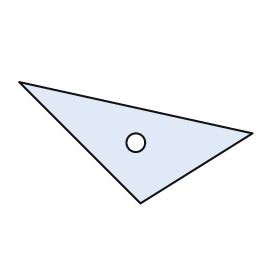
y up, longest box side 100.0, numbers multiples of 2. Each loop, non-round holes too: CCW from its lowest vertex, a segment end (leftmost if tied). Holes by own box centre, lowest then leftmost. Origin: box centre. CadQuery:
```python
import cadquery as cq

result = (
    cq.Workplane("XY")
    .moveTo(2.0, -26.0)
    .lineTo(50.0, 4.0)
    .lineTo(-50.0, 26.0)
    .close()
    .moveTo(0.0, 0.0)
    .circle(4.0)
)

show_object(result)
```